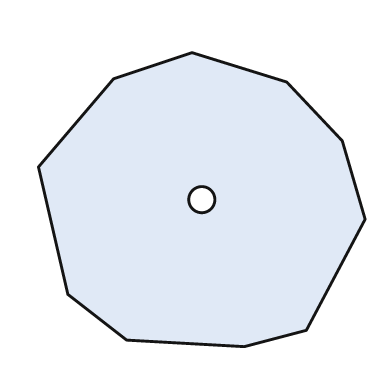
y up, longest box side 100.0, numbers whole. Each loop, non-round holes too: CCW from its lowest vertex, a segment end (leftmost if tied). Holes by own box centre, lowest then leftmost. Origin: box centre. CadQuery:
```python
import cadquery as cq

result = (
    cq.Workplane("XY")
    .moveTo(13.0, -45.0)
    .lineTo(32.0, -40.0)
    .lineTo(50.0, -6.0)
    .lineTo(43.0, 18.0)
    .lineTo(26.0, 36.0)
    .lineTo(-3.0, 45.0)
    .lineTo(-27.0, 37.0)
    .lineTo(-50.0, 10.0)
    .lineTo(-41.0, -29.0)
    .lineTo(-23.0, -43.0)
    .close()
    .moveTo(0.0, 0.0)
    .circle(4.0)
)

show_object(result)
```